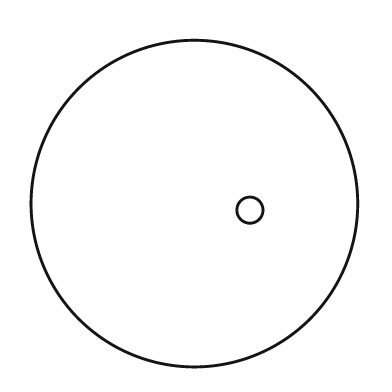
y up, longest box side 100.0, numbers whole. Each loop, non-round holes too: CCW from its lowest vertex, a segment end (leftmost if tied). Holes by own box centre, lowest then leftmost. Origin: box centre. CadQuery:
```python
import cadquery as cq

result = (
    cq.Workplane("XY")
    .moveTo(0.0, 0.0)
    .circle(50.0)
    .moveTo(17.0, -2.0)
    .circle(4.0)
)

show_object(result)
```